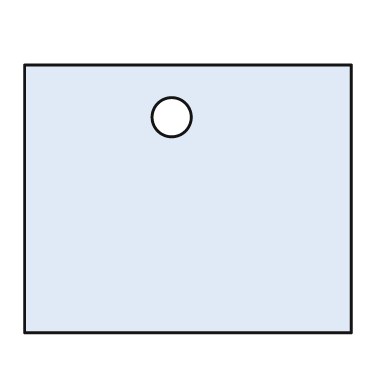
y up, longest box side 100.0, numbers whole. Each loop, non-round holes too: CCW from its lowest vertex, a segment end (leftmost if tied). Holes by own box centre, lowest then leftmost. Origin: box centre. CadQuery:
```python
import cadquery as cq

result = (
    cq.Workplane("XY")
    .moveTo(-50.0, -41.0)
    .lineTo(50.0, -41.0)
    .lineTo(50.0, 41.0)
    .lineTo(-50.0, 41.0)
    .close()
    .moveTo(-5.0, 25.0)
    .circle(6.0)
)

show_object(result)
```